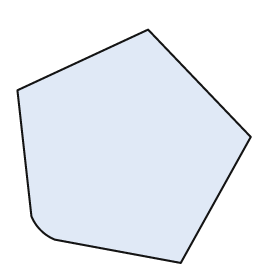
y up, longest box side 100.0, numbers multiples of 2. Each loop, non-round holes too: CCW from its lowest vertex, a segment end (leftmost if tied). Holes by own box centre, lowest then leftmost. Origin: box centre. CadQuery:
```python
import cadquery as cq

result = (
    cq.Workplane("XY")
    .moveTo(20.0, -50.0)
    .lineTo(50.0, 4.0)
    .lineTo(6.0, 50.0)
    .lineTo(-50.0, 24.0)
    .lineTo(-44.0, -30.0)
    .threePointArc((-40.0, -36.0), (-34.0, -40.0))
    .close()
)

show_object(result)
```